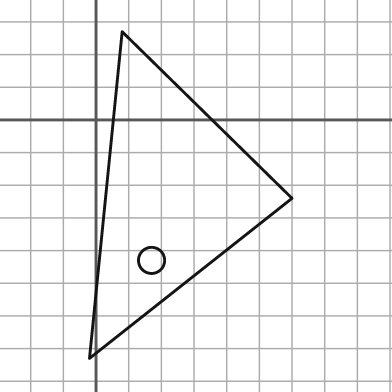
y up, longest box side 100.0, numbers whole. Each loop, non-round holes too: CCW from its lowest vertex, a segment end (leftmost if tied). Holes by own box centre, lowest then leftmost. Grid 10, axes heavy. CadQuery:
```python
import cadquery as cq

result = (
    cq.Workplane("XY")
    .moveTo(-2.0, -73.0)
    .lineTo(60.0, -24.0)
    .lineTo(8.0, 27.0)
    .close()
    .moveTo(17.0, -43.0)
    .circle(4.0)
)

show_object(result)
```